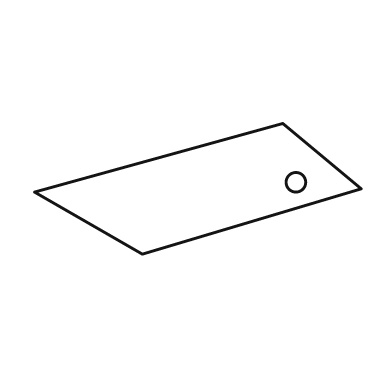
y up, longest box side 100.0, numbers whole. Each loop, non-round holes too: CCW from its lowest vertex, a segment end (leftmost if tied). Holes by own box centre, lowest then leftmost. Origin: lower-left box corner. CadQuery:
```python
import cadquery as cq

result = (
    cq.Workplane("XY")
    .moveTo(33.0, 0.0)
    .lineTo(100.0, 20.0)
    .lineTo(76.0, 40.0)
    .lineTo(0.0, 19.0)
    .close()
    .moveTo(80.0, 22.0)
    .circle(3.0)
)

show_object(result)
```